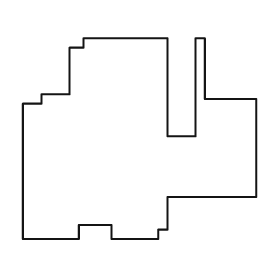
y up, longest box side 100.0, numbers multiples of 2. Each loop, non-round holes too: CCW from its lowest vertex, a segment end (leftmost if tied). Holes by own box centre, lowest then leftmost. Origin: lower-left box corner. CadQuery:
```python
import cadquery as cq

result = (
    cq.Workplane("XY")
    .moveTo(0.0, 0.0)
    .lineTo(24.0, 0.0)
    .lineTo(24.0, 6.0)
    .lineTo(38.0, 6.0)
    .lineTo(38.0, 0.0)
    .lineTo(58.0, 0.0)
    .lineTo(58.0, 4.0)
    .lineTo(62.0, 4.0)
    .lineTo(62.0, 18.0)
    .lineTo(100.0, 18.0)
    .lineTo(100.0, 60.0)
    .lineTo(78.0, 60.0)
    .lineTo(78.0, 86.0)
    .lineTo(74.0, 86.0)
    .lineTo(74.0, 44.0)
    .lineTo(62.0, 44.0)
    .lineTo(62.0, 86.0)
    .lineTo(26.0, 86.0)
    .lineTo(26.0, 82.0)
    .lineTo(20.0, 82.0)
    .lineTo(20.0, 62.0)
    .lineTo(8.0, 62.0)
    .lineTo(8.0, 58.0)
    .lineTo(0.0, 58.0)
    .close()
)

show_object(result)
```